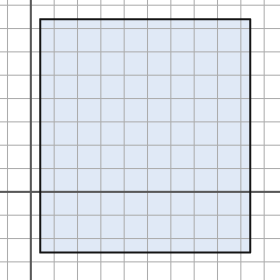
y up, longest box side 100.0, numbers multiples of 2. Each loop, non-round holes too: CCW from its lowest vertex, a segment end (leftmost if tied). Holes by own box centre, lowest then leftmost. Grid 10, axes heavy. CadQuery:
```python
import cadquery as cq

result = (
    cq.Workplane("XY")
    .moveTo(4.0, -26.0)
    .lineTo(94.0, -26.0)
    .lineTo(94.0, 74.0)
    .lineTo(4.0, 74.0)
    .close()
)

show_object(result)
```